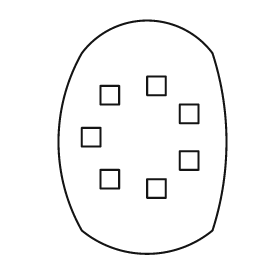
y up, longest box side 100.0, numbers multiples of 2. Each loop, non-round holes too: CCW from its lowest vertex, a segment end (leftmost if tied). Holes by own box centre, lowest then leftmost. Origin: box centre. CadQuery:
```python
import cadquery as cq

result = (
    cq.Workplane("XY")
    .moveTo(-26.0, -40.0)
    .threePointArc((2.0, -50.0), (30.0, -40.0))
    .threePointArc((36.0, -2.0), (30.0, 36.0))
    .threePointArc((2.0, 50.0), (-26.0, 36.0))
    .threePointArc((-36.0, -2.0), (-26.0, -40.0))
    .close()
    .moveTo(2.0, -26.0)
    .lineTo(10.0, -26.0)
    .lineTo(10.0, -18.0)
    .lineTo(2.0, -18.0)
    .close()
    .moveTo(-18.0, -22.0)
    .lineTo(-10.0, -22.0)
    .lineTo(-10.0, -14.0)
    .lineTo(-18.0, -14.0)
    .close()
    .moveTo(16.0, -14.0)
    .lineTo(24.0, -14.0)
    .lineTo(24.0, -6.0)
    .lineTo(16.0, -6.0)
    .close()
    .moveTo(-26.0, -4.0)
    .lineTo(-18.0, -4.0)
    .lineTo(-18.0, 4.0)
    .lineTo(-26.0, 4.0)
    .close()
    .moveTo(16.0, 6.0)
    .lineTo(24.0, 6.0)
    .lineTo(24.0, 14.0)
    .lineTo(16.0, 14.0)
    .close()
    .moveTo(-18.0, 14.0)
    .lineTo(-10.0, 14.0)
    .lineTo(-10.0, 22.0)
    .lineTo(-18.0, 22.0)
    .close()
    .moveTo(2.0, 18.0)
    .lineTo(10.0, 18.0)
    .lineTo(10.0, 26.0)
    .lineTo(2.0, 26.0)
    .close()
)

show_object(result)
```